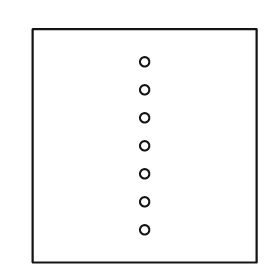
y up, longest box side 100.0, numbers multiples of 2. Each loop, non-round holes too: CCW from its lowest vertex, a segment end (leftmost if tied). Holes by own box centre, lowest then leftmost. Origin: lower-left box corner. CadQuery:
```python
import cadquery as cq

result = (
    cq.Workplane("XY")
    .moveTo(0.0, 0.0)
    .lineTo(96.0, 0.0)
    .lineTo(96.0, 100.0)
    .lineTo(0.0, 100.0)
    .close()
    .moveTo(48.0, 14.0)
    .circle(2.0)
    .moveTo(48.0, 26.0)
    .circle(2.0)
    .moveTo(48.0, 38.0)
    .circle(2.0)
    .moveTo(48.0, 50.0)
    .circle(2.0)
    .moveTo(48.0, 62.0)
    .circle(2.0)
    .moveTo(48.0, 74.0)
    .circle(2.0)
    .moveTo(48.0, 86.0)
    .circle(2.0)
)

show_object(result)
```